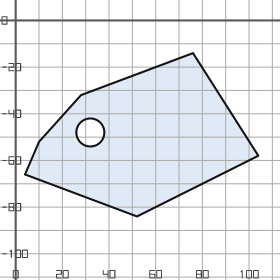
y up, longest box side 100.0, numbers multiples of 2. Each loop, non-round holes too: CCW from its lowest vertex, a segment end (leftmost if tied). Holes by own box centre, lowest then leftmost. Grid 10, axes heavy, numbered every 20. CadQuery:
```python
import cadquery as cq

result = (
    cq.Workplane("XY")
    .moveTo(52.0, -84.0)
    .lineTo(104.0, -58.0)
    .lineTo(76.0, -14.0)
    .lineTo(28.0, -32.0)
    .lineTo(10.0, -52.0)
    .lineTo(4.0, -66.0)
    .close()
    .moveTo(32.0, -48.0)
    .circle(6.0)
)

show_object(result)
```